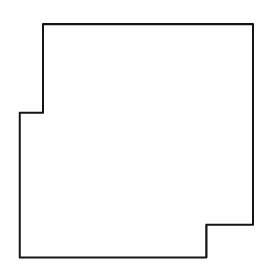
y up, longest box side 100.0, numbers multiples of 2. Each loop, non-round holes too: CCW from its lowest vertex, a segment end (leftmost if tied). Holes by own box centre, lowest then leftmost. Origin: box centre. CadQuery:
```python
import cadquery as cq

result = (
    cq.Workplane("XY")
    .moveTo(-50.0, -50.0)
    .lineTo(30.0, -50.0)
    .lineTo(30.0, -36.0)
    .lineTo(50.0, -36.0)
    .lineTo(50.0, 50.0)
    .lineTo(-40.0, 50.0)
    .lineTo(-40.0, 12.0)
    .lineTo(-50.0, 12.0)
    .close()
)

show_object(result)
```